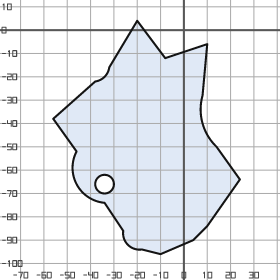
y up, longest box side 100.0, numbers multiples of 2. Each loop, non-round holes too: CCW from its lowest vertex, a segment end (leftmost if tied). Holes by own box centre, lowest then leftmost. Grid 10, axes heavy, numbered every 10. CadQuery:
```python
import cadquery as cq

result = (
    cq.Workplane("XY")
    .moveTo(-10.0, -96.0)
    .lineTo(4.0, -90.0)
    .lineTo(10.0, -84.0)
    .lineTo(24.0, -64.0)
    .lineTo(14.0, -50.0)
    .threePointArc((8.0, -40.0), (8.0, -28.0))
    .lineTo(10.0, -6.0)
    .lineTo(-8.0, -12.0)
    .lineTo(-20.0, 4.0)
    .lineTo(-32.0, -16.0)
    .threePointArc((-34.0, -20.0), (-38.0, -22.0))
    .lineTo(-56.0, -38.0)
    .lineTo(-46.0, -52.0)
    .threePointArc((-46.0, -66.0), (-34.0, -74.0))
    .lineTo(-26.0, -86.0)
    .threePointArc((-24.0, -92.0), (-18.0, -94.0))
    .close()
    .moveTo(-34.0, -66.0)
    .circle(4.0)
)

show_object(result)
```